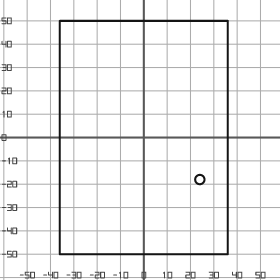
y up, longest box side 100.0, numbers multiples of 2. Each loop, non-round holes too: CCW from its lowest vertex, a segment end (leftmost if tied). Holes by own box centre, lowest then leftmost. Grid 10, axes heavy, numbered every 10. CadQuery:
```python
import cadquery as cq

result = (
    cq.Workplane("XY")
    .moveTo(-36.0, -50.0)
    .lineTo(36.0, -50.0)
    .lineTo(36.0, 50.0)
    .lineTo(-36.0, 50.0)
    .close()
    .moveTo(24.0, -18.0)
    .circle(2.0)
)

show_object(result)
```